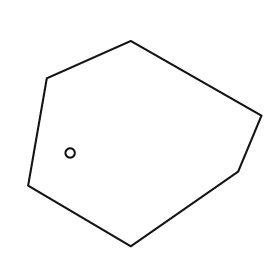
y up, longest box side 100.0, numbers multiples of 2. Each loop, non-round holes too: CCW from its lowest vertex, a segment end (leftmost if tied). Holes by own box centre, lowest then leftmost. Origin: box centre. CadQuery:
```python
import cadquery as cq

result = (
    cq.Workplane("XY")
    .moveTo(-6.0, -44.0)
    .lineTo(40.0, -12.0)
    .lineTo(50.0, 12.0)
    .lineTo(-6.0, 44.0)
    .lineTo(-42.0, 28.0)
    .lineTo(-50.0, -18.0)
    .close()
    .moveTo(-32.0, -4.0)
    .circle(2.0)
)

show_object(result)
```